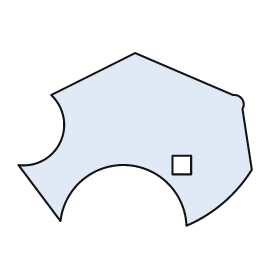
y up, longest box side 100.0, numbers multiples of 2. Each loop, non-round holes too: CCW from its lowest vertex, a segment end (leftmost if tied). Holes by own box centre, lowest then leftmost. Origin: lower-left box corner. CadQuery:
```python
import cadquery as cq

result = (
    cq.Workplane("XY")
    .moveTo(72.0, 0.0)
    .threePointArc((88.0, 10.0), (100.0, 24.0))
    .lineTo(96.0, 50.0)
    .threePointArc((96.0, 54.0), (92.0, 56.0))
    .lineTo(50.0, 74.0)
    .lineTo(14.0, 56.0)
    .threePointArc((18.0, 36.0), (0.0, 26.0))
    .lineTo(18.0, 2.0)
    .threePointArc((46.0, 26.0), (72.0, 0.0))
    .close()
    .moveTo(66.0, 22.0)
    .lineTo(74.0, 22.0)
    .lineTo(74.0, 30.0)
    .lineTo(66.0, 30.0)
    .close()
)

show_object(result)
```